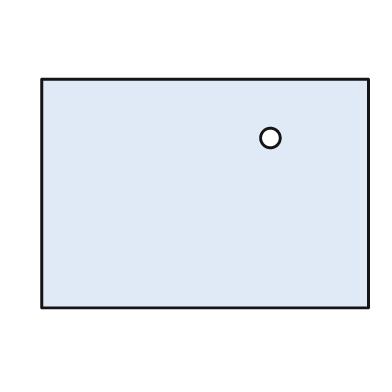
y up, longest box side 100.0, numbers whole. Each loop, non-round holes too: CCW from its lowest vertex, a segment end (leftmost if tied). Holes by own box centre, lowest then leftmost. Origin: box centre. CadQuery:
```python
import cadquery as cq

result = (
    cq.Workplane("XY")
    .moveTo(-50.0, -35.0)
    .lineTo(50.0, -35.0)
    .lineTo(50.0, 35.0)
    .lineTo(-50.0, 35.0)
    .close()
    .moveTo(20.0, 17.0)
    .circle(3.0)
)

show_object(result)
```